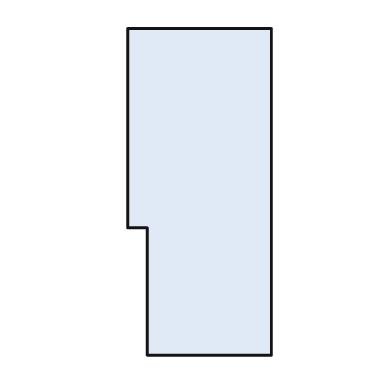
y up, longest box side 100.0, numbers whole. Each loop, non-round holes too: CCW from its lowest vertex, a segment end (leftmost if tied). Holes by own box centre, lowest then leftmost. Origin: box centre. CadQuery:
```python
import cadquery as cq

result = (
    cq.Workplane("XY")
    .moveTo(-16.0, -50.0)
    .lineTo(22.0, -50.0)
    .lineTo(22.0, 50.0)
    .lineTo(-22.0, 50.0)
    .lineTo(-22.0, -11.0)
    .lineTo(-16.0, -11.0)
    .close()
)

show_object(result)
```